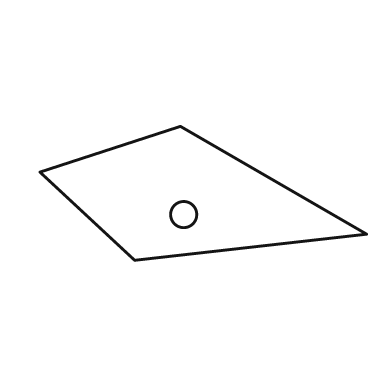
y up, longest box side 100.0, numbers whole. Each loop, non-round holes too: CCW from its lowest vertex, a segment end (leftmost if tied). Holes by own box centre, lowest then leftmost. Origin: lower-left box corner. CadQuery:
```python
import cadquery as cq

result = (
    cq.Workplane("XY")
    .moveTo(29.0, 0.0)
    .lineTo(100.0, 8.0)
    .lineTo(43.0, 41.0)
    .lineTo(0.0, 27.0)
    .close()
    .moveTo(44.0, 14.0)
    .circle(4.0)
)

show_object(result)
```